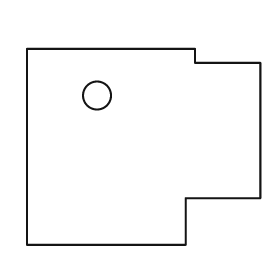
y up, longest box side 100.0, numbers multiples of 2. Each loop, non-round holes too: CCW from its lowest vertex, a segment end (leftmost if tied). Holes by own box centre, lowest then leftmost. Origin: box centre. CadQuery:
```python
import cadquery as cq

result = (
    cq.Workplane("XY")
    .moveTo(-50.0, -42.0)
    .lineTo(18.0, -42.0)
    .lineTo(18.0, -22.0)
    .lineTo(50.0, -22.0)
    .lineTo(50.0, 36.0)
    .lineTo(22.0, 36.0)
    .lineTo(22.0, 42.0)
    .lineTo(-50.0, 42.0)
    .close()
    .moveTo(-20.0, 22.0)
    .circle(6.0)
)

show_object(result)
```